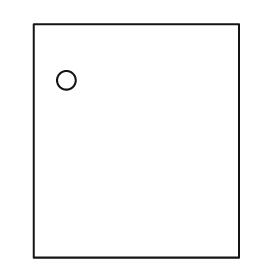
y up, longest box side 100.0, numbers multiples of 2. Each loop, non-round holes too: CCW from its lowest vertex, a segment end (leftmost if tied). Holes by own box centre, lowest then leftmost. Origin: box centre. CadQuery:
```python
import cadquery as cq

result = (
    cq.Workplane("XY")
    .moveTo(-44.0, -50.0)
    .lineTo(44.0, -50.0)
    .lineTo(44.0, 50.0)
    .lineTo(-44.0, 50.0)
    .close()
    .moveTo(-30.0, 26.0)
    .circle(4.0)
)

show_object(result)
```